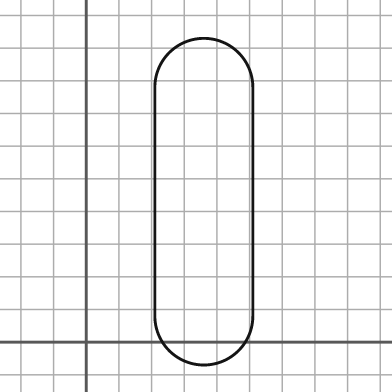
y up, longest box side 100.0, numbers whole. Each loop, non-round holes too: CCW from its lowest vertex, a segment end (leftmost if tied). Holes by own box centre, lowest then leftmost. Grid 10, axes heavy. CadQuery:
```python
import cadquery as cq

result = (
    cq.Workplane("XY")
    .moveTo(21.0, 8.0)
    .threePointArc((36.0, -7.0), (51.0, 8.0))
    .lineTo(51.0, 78.0)
    .threePointArc((36.0, 93.0), (21.0, 78.0))
    .close()
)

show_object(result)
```